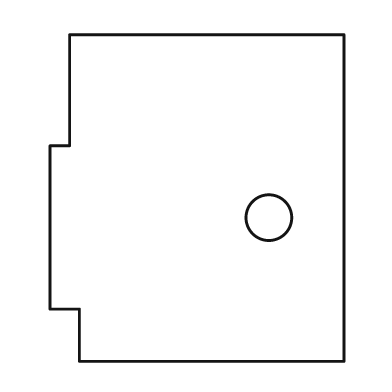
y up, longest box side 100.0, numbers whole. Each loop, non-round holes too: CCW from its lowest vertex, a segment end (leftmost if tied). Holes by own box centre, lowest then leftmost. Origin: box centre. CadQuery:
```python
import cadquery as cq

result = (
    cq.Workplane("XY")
    .moveTo(-36.0, -50.0)
    .lineTo(45.0, -50.0)
    .lineTo(45.0, 50.0)
    .lineTo(-39.0, 50.0)
    .lineTo(-39.0, 16.0)
    .lineTo(-45.0, 16.0)
    .lineTo(-45.0, -34.0)
    .lineTo(-36.0, -34.0)
    .close()
    .moveTo(22.0, -6.0)
    .circle(7.0)
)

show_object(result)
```